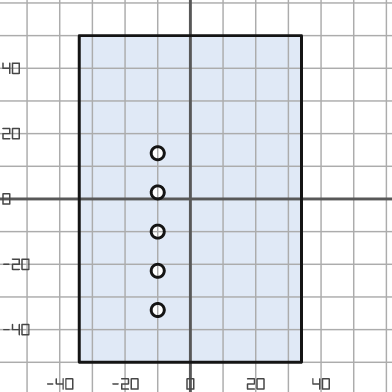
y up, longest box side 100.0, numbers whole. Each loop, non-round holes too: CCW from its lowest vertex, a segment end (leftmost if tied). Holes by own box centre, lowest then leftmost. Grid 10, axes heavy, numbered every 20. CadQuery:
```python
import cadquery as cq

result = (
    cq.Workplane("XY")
    .moveTo(-34.0, -50.0)
    .lineTo(34.0, -50.0)
    .lineTo(34.0, 50.0)
    .lineTo(-34.0, 50.0)
    .close()
    .moveTo(-10.0, -34.0)
    .circle(2.0)
    .moveTo(-10.0, -22.0)
    .circle(2.0)
    .moveTo(-10.0, -10.0)
    .circle(2.0)
    .moveTo(-10.0, 2.0)
    .circle(2.0)
    .moveTo(-10.0, 14.0)
    .circle(2.0)
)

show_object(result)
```